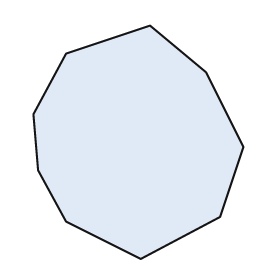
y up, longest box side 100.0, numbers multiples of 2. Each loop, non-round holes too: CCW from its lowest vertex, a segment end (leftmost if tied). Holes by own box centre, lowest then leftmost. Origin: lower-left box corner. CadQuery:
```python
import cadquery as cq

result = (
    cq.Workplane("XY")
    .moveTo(46.0, 0.0)
    .lineTo(80.0, 18.0)
    .lineTo(90.0, 48.0)
    .lineTo(74.0, 80.0)
    .lineTo(50.0, 100.0)
    .lineTo(14.0, 88.0)
    .lineTo(0.0, 62.0)
    .lineTo(2.0, 38.0)
    .lineTo(14.0, 16.0)
    .close()
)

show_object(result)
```